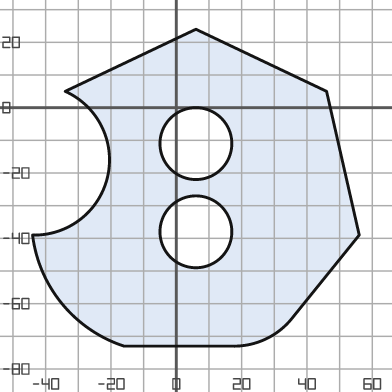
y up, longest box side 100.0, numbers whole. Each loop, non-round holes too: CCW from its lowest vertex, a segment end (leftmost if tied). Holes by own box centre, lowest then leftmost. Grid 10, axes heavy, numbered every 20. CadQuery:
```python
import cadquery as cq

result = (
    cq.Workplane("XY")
    .moveTo(-16.0, -73.0)
    .lineTo(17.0, -73.0)
    .threePointArc((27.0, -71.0), (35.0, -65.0))
    .lineTo(56.0, -39.0)
    .lineTo(46.0, 5.0)
    .lineTo(6.0, 24.0)
    .lineTo(-34.0, 5.0)
    .threePointArc((-21.0, -21.0), (-44.0, -39.0))
    .threePointArc((-35.0, -60.0), (-16.0, -73.0))
    .close()
    .moveTo(6.0, -38.0)
    .circle(11.0)
    .moveTo(6.0, -11.0)
    .circle(11.0)
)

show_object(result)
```